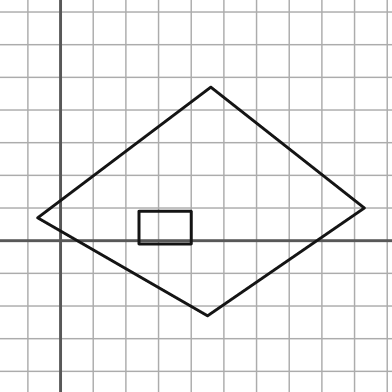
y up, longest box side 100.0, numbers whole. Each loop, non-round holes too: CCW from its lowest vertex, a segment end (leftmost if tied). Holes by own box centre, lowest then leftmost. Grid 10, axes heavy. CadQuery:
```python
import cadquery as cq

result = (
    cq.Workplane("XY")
    .moveTo(45.0, -23.0)
    .lineTo(93.0, 10.0)
    .lineTo(46.0, 47.0)
    .lineTo(-7.0, 7.0)
    .close()
    .moveTo(24.0, -1.0)
    .lineTo(40.0, -1.0)
    .lineTo(40.0, 9.0)
    .lineTo(24.0, 9.0)
    .close()
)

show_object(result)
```